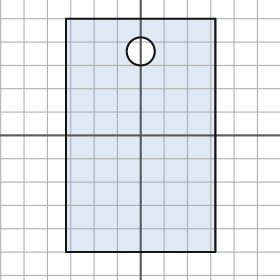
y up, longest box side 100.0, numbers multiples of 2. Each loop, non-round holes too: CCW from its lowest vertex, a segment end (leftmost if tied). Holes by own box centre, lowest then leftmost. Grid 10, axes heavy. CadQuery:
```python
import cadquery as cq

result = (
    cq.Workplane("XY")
    .moveTo(-32.0, -50.0)
    .lineTo(32.0, -50.0)
    .lineTo(32.0, 50.0)
    .lineTo(-32.0, 50.0)
    .close()
    .moveTo(0.0, 36.0)
    .circle(6.0)
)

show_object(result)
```